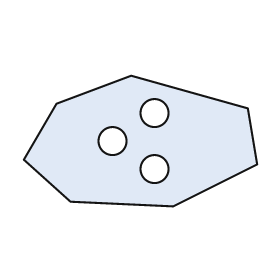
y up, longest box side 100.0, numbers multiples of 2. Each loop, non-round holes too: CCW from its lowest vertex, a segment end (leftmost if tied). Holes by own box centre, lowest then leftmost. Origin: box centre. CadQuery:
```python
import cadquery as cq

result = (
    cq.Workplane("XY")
    .moveTo(14.0, -28.0)
    .lineTo(50.0, -10.0)
    .lineTo(46.0, 14.0)
    .lineTo(-4.0, 28.0)
    .lineTo(-36.0, 16.0)
    .lineTo(-50.0, -8.0)
    .lineTo(-30.0, -26.0)
    .close()
    .moveTo(6.0, -12.0)
    .circle(6.0)
    .moveTo(-12.0, 0.0)
    .circle(6.0)
    .moveTo(6.0, 12.0)
    .circle(6.0)
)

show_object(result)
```